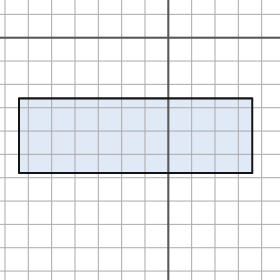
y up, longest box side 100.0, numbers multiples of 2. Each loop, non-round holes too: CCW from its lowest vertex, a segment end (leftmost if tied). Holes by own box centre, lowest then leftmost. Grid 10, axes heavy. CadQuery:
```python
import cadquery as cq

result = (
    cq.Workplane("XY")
    .moveTo(-64.0, -58.0)
    .lineTo(36.0, -58.0)
    .lineTo(36.0, -26.0)
    .lineTo(-64.0, -26.0)
    .close()
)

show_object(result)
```